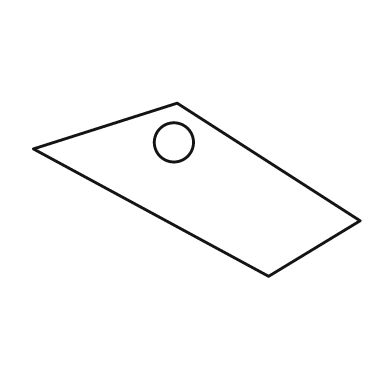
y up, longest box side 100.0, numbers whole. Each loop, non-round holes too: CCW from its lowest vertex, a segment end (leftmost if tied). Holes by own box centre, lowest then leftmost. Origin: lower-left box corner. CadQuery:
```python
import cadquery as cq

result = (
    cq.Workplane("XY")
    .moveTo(72.0, 0.0)
    .lineTo(100.0, 17.0)
    .lineTo(44.0, 53.0)
    .lineTo(0.0, 39.0)
    .close()
    .moveTo(43.0, 41.0)
    .circle(6.0)
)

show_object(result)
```